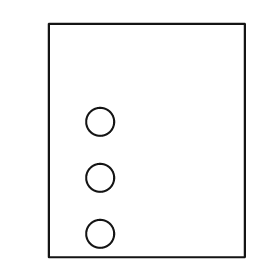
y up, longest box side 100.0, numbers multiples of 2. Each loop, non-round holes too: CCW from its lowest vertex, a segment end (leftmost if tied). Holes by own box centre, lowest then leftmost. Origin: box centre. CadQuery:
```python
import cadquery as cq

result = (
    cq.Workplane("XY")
    .moveTo(-42.0, -50.0)
    .lineTo(42.0, -50.0)
    .lineTo(42.0, 50.0)
    .lineTo(-42.0, 50.0)
    .close()
    .moveTo(-20.0, -40.0)
    .circle(6.0)
    .moveTo(-20.0, -16.0)
    .circle(6.0)
    .moveTo(-20.0, 8.0)
    .circle(6.0)
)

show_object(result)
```